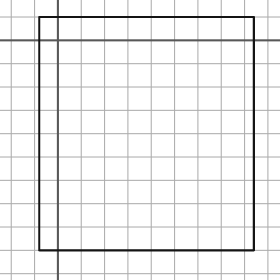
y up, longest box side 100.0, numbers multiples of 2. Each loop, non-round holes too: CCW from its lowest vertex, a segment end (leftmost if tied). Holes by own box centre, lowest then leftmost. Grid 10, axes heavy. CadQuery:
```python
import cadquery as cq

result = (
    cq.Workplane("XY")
    .moveTo(-8.0, -90.0)
    .lineTo(84.0, -90.0)
    .lineTo(84.0, 10.0)
    .lineTo(-8.0, 10.0)
    .close()
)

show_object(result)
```